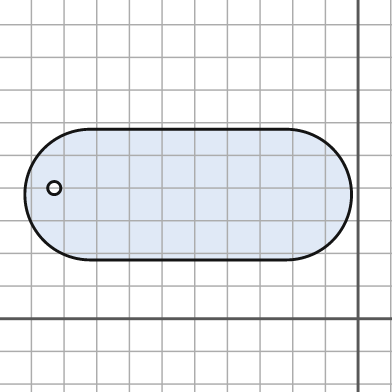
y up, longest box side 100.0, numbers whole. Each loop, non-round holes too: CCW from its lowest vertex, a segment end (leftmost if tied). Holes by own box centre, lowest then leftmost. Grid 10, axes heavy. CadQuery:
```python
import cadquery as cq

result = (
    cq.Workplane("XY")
    .moveTo(-82.0, 18.0)
    .lineTo(-22.0, 18.0)
    .threePointArc((-2.0, 38.0), (-22.0, 58.0))
    .lineTo(-82.0, 58.0)
    .threePointArc((-102.0, 38.0), (-82.0, 18.0))
    .close()
    .moveTo(-93.0, 40.0)
    .circle(2.0)
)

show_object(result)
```